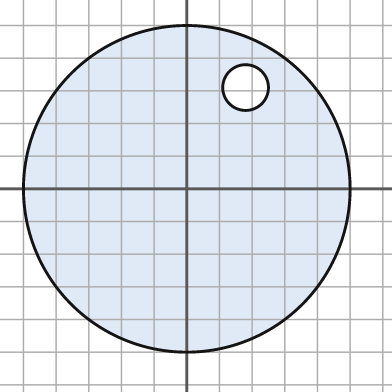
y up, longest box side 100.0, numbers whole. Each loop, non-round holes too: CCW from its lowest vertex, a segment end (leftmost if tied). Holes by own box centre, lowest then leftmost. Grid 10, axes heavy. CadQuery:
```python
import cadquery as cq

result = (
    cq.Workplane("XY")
    .moveTo(0.0, 0.0)
    .circle(50.0)
    .moveTo(18.0, 31.0)
    .circle(7.0)
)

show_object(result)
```